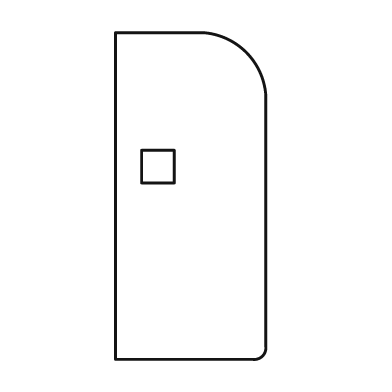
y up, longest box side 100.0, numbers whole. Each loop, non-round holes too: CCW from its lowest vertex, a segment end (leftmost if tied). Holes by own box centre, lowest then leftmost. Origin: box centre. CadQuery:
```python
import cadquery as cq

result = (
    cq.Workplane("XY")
    .moveTo(-23.0, -50.0)
    .lineTo(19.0, -50.0)
    .threePointArc((22.0, -49.0), (23.0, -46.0))
    .lineTo(23.0, 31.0)
    .threePointArc((17.0, 44.0), (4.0, 50.0))
    .lineTo(-23.0, 50.0)
    .close()
    .moveTo(-15.0, 4.0)
    .lineTo(-5.0, 4.0)
    .lineTo(-5.0, 14.0)
    .lineTo(-15.0, 14.0)
    .close()
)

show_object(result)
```